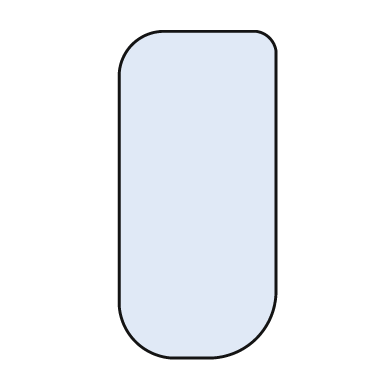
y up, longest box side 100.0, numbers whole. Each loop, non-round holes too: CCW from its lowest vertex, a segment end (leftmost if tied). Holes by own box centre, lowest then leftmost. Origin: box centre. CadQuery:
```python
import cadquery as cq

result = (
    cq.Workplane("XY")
    .moveTo(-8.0, -50.0)
    .lineTo(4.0, -50.0)
    .threePointArc((18.0, -44.0), (24.0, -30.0))
    .lineTo(24.0, 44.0)
    .threePointArc((22.0, 48.0), (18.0, 50.0))
    .lineTo(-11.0, 50.0)
    .threePointArc((-20.0, 46.0), (-24.0, 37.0))
    .lineTo(-24.0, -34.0)
    .threePointArc((-19.0, -45.0), (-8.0, -50.0))
    .close()
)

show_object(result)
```